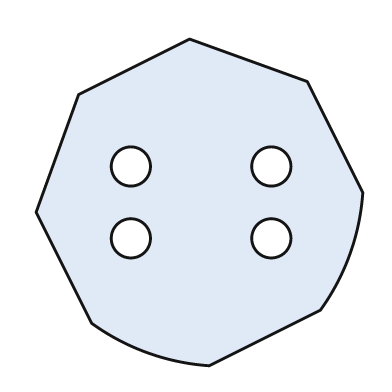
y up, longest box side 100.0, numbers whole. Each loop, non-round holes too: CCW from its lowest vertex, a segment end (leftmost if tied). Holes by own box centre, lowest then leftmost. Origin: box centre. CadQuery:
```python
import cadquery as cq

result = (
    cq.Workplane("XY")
    .moveTo(3.0, -50.0)
    .lineTo(37.0, -33.0)
    .threePointArc((46.0, -16.0), (50.0, 3.0))
    .lineTo(33.0, 37.0)
    .lineTo(-3.0, 50.0)
    .lineTo(-37.0, 33.0)
    .lineTo(-50.0, -3.0)
    .lineTo(-33.0, -37.0)
    .threePointArc((-16.0, -46.0), (3.0, -50.0))
    .close()
    .moveTo(-21.0, -11.0)
    .circle(6.0)
    .moveTo(22.0, -11.0)
    .circle(6.0)
    .moveTo(-21.0, 11.0)
    .circle(6.0)
    .moveTo(22.0, 11.0)
    .circle(6.0)
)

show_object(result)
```